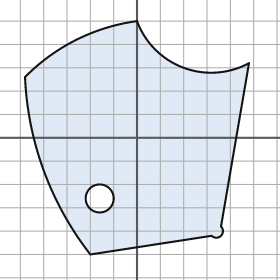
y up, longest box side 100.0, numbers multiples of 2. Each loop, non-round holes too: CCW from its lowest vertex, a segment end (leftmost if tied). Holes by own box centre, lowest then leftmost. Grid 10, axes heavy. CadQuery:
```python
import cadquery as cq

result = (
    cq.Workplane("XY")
    .moveTo(-20.0, -50.0)
    .lineTo(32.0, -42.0)
    .threePointArc((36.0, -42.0), (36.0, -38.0))
    .lineTo(48.0, 32.0)
    .threePointArc((20.0, 30.0), (0.0, 50.0))
    .threePointArc((-26.0, 42.0), (-48.0, 26.0))
    .threePointArc((-40.0, -14.0), (-20.0, -50.0))
    .close()
    .moveTo(-16.0, -26.0)
    .circle(6.0)
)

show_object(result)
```